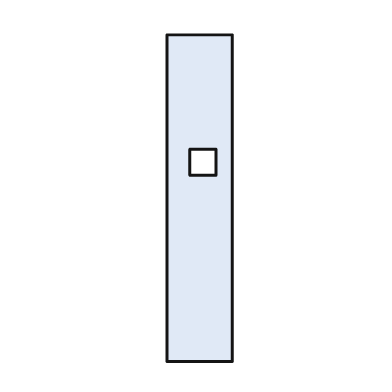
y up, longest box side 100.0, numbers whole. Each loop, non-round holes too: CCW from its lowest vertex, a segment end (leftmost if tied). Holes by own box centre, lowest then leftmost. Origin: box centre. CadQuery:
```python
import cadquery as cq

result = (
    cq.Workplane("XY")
    .moveTo(-10.0, -50.0)
    .lineTo(10.0, -50.0)
    .lineTo(10.0, 50.0)
    .lineTo(-10.0, 50.0)
    .close()
    .moveTo(-3.0, 7.0)
    .lineTo(5.0, 7.0)
    .lineTo(5.0, 15.0)
    .lineTo(-3.0, 15.0)
    .close()
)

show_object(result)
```